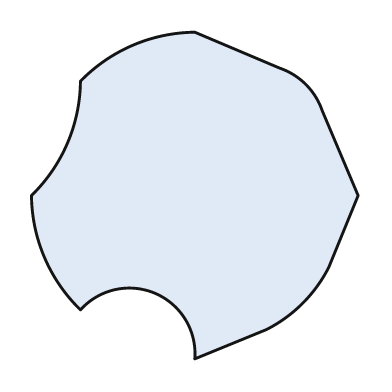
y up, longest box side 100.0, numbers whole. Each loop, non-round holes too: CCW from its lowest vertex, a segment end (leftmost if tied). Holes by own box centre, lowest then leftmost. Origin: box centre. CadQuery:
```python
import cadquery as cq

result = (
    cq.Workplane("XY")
    .moveTo(0.0, -50.0)
    .lineTo(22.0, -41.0)
    .threePointArc((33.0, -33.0), (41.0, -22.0))
    .lineTo(50.0, 0.0)
    .lineTo(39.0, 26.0)
    .threePointArc((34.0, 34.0), (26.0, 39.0))
    .lineTo(0.0, 50.0)
    .threePointArc((-19.0, 46.0), (-35.0, 35.0))
    .threePointArc((-39.0, 16.0), (-50.0, 0.0))
    .threePointArc((-46.0, -19.0), (-35.0, -35.0))
    .threePointArc((-12.0, -30.0), (0.0, -50.0))
    .close()
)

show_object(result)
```